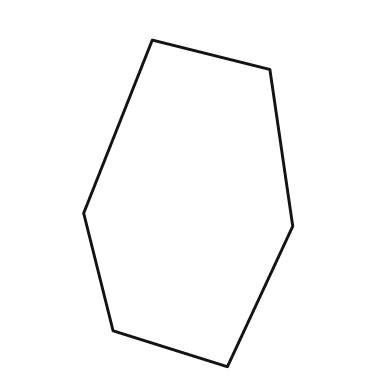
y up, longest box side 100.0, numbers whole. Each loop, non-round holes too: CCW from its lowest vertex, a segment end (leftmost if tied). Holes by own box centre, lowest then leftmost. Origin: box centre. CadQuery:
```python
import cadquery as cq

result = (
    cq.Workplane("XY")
    .moveTo(12.0, -50.0)
    .lineTo(32.0, -7.0)
    .lineTo(25.0, 41.0)
    .lineTo(-11.0, 50.0)
    .lineTo(-32.0, -3.0)
    .lineTo(-23.0, -39.0)
    .close()
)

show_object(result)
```